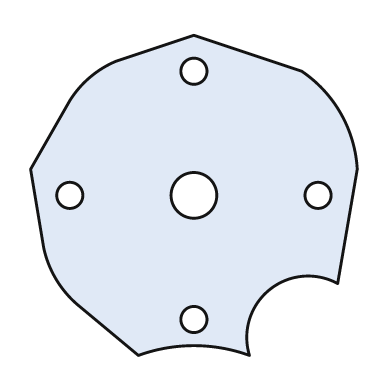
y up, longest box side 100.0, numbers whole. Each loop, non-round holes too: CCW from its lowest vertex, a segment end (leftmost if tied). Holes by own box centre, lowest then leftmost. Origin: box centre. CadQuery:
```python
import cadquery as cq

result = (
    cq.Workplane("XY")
    .moveTo(-17.0, -49.0)
    .threePointArc((0.0, -46.0), (17.0, -49.0))
    .threePointArc((23.0, -29.0), (44.0, -27.0))
    .lineTo(50.0, 8.0)
    .threePointArc((45.0, 25.0), (33.0, 38.0))
    .lineTo(0.0, 49.0)
    .lineTo(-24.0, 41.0)
    .threePointArc((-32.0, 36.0), (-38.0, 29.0))
    .lineTo(-50.0, 8.0)
    .lineTo(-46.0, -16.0)
    .threePointArc((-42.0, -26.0), (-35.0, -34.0))
    .close()
    .moveTo(0.0, -38.0)
    .circle(4.0)
    .moveTo(-38.0, 0.0)
    .circle(4.0)
    .moveTo(0.0, 0.0)
    .circle(7.0)
    .moveTo(38.0, 0.0)
    .circle(4.0)
    .moveTo(0.0, 38.0)
    .circle(4.0)
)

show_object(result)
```